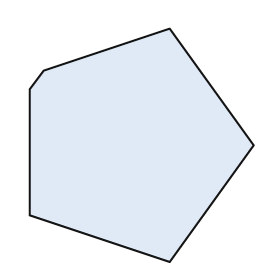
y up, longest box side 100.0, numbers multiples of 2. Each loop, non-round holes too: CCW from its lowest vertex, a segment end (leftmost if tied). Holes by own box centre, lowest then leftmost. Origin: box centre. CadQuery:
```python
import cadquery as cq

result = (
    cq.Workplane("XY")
    .moveTo(12.0, -50.0)
    .lineTo(48.0, 0.0)
    .lineTo(12.0, 50.0)
    .lineTo(-42.0, 32.0)
    .lineTo(-48.0, 24.0)
    .lineTo(-48.0, -30.0)
    .close()
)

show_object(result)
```